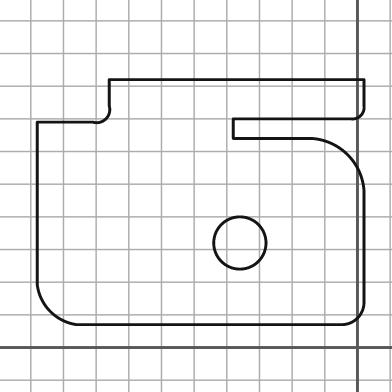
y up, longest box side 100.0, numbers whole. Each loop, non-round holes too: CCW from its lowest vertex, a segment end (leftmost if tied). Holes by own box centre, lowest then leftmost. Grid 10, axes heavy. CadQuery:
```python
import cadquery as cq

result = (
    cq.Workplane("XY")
    .moveTo(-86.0, 7.0)
    .lineTo(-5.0, 7.0)
    .threePointArc((0.0, 9.0), (2.0, 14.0))
    .lineTo(2.0, 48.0)
    .threePointArc((-3.0, 59.0), (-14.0, 64.0))
    .lineTo(-38.0, 64.0)
    .lineTo(-38.0, 70.0)
    .lineTo(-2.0, 70.0)
    .threePointArc((1.0, 71.0), (2.0, 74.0))
    .lineTo(2.0, 82.0)
    .lineTo(-76.0, 82.0)
    .lineTo(-76.0, 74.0)
    .threePointArc((-77.0, 70.0), (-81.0, 69.0))
    .lineTo(-98.0, 69.0)
    .lineTo(-98.0, 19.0)
    .threePointArc((-94.0, 11.0), (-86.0, 7.0))
    .close()
    .moveTo(-36.0, 32.0)
    .circle(8.0)
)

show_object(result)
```